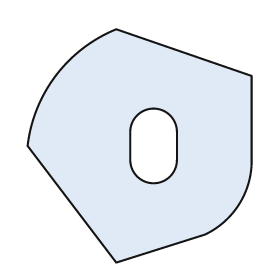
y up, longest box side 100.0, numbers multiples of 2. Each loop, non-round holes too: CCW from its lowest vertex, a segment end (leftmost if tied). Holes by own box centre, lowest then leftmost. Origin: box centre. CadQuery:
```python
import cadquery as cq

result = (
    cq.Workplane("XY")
    .moveTo(-10.0, -50.0)
    .lineTo(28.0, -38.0)
    .threePointArc((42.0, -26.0), (48.0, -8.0))
    .lineTo(48.0, 30.0)
    .lineTo(-10.0, 50.0)
    .threePointArc((-36.0, 30.0), (-48.0, 0.0))
    .close()
    .moveTo(-4.0, -6.0)
    .threePointArc((6.0, -16.0), (16.0, -6.0))
    .lineTo(16.0, 6.0)
    .threePointArc((6.0, 16.0), (-4.0, 6.0))
    .close()
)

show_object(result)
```